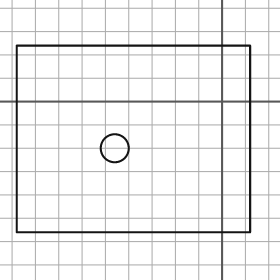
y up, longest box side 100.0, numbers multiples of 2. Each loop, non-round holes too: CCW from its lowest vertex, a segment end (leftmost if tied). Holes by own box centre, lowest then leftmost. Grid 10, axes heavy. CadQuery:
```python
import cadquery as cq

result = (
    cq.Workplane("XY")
    .moveTo(-88.0, -56.0)
    .lineTo(12.0, -56.0)
    .lineTo(12.0, 24.0)
    .lineTo(-88.0, 24.0)
    .close()
    .moveTo(-46.0, -20.0)
    .circle(6.0)
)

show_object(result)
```